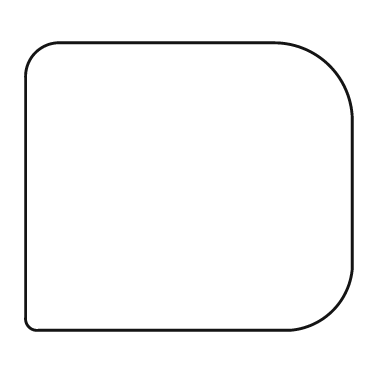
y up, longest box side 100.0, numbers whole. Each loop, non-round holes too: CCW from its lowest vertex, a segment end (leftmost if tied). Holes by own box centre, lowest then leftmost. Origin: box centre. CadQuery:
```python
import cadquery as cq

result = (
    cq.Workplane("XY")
    .moveTo(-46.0, -44.0)
    .lineTo(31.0, -44.0)
    .threePointArc((44.0, -38.0), (50.0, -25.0))
    .lineTo(50.0, 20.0)
    .threePointArc((43.0, 37.0), (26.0, 44.0))
    .lineTo(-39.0, 44.0)
    .threePointArc((-47.0, 41.0), (-50.0, 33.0))
    .lineTo(-50.0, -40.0)
    .threePointArc((-49.0, -43.0), (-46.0, -44.0))
    .close()
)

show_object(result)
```